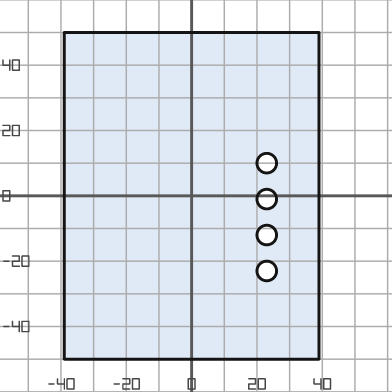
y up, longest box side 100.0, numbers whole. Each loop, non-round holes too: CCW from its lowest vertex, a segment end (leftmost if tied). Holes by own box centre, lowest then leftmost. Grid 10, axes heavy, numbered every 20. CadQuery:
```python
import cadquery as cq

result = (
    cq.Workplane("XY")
    .moveTo(-39.0, -50.0)
    .lineTo(39.0, -50.0)
    .lineTo(39.0, 50.0)
    .lineTo(-39.0, 50.0)
    .close()
    .moveTo(23.0, -23.0)
    .circle(3.0)
    .moveTo(23.0, -12.0)
    .circle(3.0)
    .moveTo(23.0, -1.0)
    .circle(3.0)
    .moveTo(23.0, 10.0)
    .circle(3.0)
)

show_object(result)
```